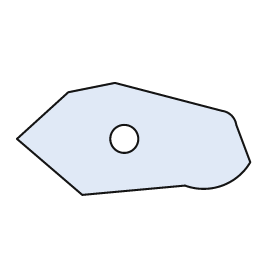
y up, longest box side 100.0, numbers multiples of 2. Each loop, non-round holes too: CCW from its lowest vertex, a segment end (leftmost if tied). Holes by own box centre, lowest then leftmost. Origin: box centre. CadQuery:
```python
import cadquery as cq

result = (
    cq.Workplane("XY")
    .moveTo(-22.0, -24.0)
    .lineTo(22.0, -20.0)
    .threePointArc((38.0, -20.0), (50.0, -10.0))
    .lineTo(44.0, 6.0)
    .threePointArc((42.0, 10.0), (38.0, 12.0))
    .lineTo(-8.0, 24.0)
    .lineTo(-28.0, 20.0)
    .lineTo(-50.0, 0.0)
    .close()
    .moveTo(-4.0, 0.0)
    .circle(6.0)
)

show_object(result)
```